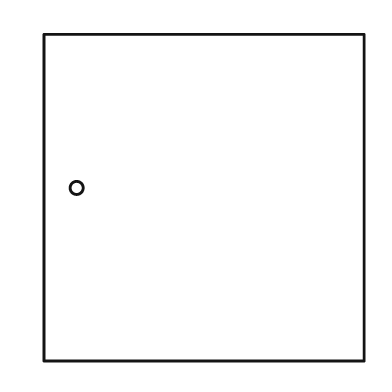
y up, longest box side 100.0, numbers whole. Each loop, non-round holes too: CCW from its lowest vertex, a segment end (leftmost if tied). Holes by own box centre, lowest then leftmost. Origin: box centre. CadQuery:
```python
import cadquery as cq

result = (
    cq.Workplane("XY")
    .moveTo(-49.0, -50.0)
    .lineTo(49.0, -50.0)
    .lineTo(49.0, 50.0)
    .lineTo(-49.0, 50.0)
    .close()
    .moveTo(-39.0, 3.0)
    .circle(2.0)
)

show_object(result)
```